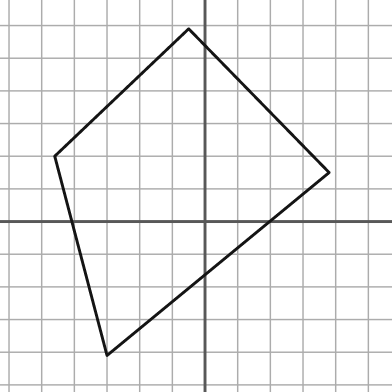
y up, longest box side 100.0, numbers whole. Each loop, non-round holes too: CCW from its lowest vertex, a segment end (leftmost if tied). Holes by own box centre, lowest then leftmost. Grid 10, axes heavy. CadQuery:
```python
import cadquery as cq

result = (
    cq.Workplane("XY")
    .moveTo(-30.0, -41.0)
    .lineTo(38.0, 15.0)
    .lineTo(-5.0, 59.0)
    .lineTo(-46.0, 20.0)
    .close()
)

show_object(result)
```